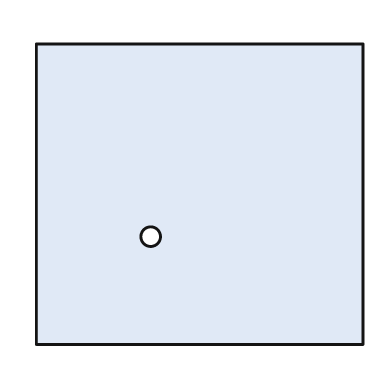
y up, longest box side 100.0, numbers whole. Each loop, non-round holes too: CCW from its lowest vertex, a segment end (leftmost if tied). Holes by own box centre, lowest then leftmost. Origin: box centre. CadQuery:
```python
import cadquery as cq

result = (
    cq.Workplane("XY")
    .moveTo(-50.0, -46.0)
    .lineTo(50.0, -46.0)
    .lineTo(50.0, 46.0)
    .lineTo(-50.0, 46.0)
    .close()
    .moveTo(-15.0, -13.0)
    .circle(3.0)
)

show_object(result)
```